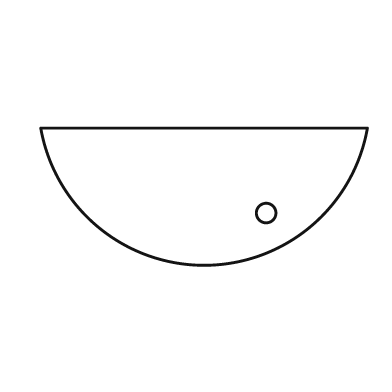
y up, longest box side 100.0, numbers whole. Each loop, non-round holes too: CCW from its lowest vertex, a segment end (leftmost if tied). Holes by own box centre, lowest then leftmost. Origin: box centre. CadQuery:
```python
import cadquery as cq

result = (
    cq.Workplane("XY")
    .moveTo(-50.0, 21.0)
    .threePointArc((0.0, -21.0), (50.0, 21.0))
    .close()
    .moveTo(19.0, -5.0)
    .circle(3.0)
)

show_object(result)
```